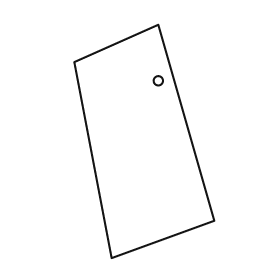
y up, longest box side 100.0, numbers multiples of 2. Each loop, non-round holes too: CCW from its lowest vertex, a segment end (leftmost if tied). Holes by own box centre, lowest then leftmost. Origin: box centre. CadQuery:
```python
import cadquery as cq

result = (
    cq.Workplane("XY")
    .moveTo(-14.0, -50.0)
    .lineTo(30.0, -34.0)
    .lineTo(6.0, 50.0)
    .lineTo(-30.0, 34.0)
    .close()
    .moveTo(6.0, 26.0)
    .circle(2.0)
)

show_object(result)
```